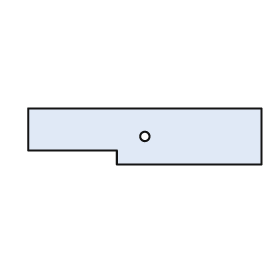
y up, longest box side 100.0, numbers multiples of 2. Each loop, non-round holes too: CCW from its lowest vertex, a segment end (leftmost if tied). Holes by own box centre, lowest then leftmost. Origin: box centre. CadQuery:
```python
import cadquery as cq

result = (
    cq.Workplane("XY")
    .moveTo(-12.0, -12.0)
    .lineTo(50.0, -12.0)
    .lineTo(50.0, 12.0)
    .lineTo(-50.0, 12.0)
    .lineTo(-50.0, -6.0)
    .lineTo(-12.0, -6.0)
    .close()
    .moveTo(0.0, 0.0)
    .circle(2.0)
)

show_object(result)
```